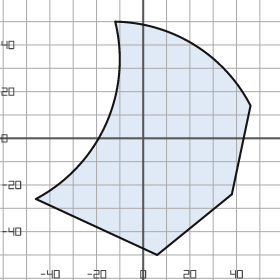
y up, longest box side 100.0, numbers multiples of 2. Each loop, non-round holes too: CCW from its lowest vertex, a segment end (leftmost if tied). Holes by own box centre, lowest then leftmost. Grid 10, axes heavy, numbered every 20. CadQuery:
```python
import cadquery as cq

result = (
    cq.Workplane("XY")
    .moveTo(6.0, -50.0)
    .lineTo(38.0, -24.0)
    .lineTo(46.0, 14.0)
    .threePointArc((22.0, 40.0), (-12.0, 50.0))
    .threePointArc((-16.0, 6.0), (-46.0, -26.0))
    .close()
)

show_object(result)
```